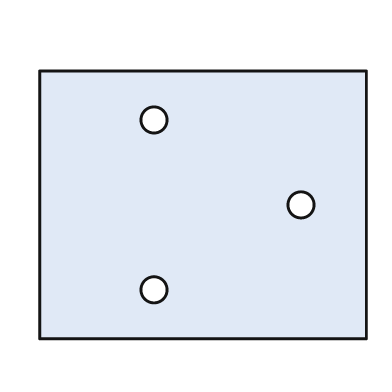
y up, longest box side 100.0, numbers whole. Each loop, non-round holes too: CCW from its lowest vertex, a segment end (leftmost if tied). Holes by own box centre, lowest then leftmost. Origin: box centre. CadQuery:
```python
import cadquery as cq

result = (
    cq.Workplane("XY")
    .moveTo(-50.0, -41.0)
    .lineTo(50.0, -41.0)
    .lineTo(50.0, 41.0)
    .lineTo(-50.0, 41.0)
    .close()
    .moveTo(-15.0, -26.0)
    .circle(4.0)
    .moveTo(30.0, 0.0)
    .circle(4.0)
    .moveTo(-15.0, 26.0)
    .circle(4.0)
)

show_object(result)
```